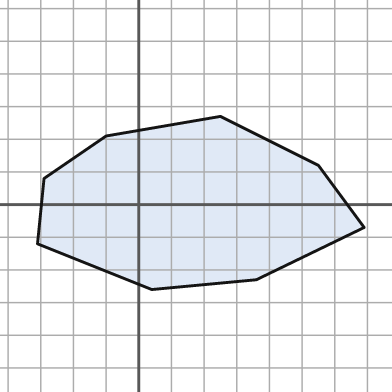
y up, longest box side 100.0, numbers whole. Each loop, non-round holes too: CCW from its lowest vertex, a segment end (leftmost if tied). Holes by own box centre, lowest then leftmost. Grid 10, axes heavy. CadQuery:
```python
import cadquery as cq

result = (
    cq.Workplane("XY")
    .moveTo(4.0, -26.0)
    .lineTo(36.0, -23.0)
    .lineTo(69.0, -7.0)
    .lineTo(55.0, 12.0)
    .lineTo(25.0, 27.0)
    .lineTo(-10.0, 21.0)
    .lineTo(-29.0, 8.0)
    .lineTo(-31.0, -12.0)
    .close()
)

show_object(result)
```